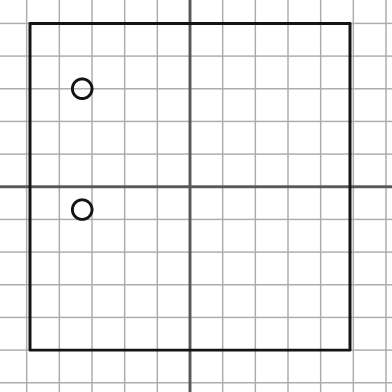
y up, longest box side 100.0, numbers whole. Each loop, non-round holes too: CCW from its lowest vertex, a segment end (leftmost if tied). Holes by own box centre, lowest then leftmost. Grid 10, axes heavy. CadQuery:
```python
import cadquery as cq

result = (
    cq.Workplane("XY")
    .moveTo(-49.0, -50.0)
    .lineTo(49.0, -50.0)
    .lineTo(49.0, 50.0)
    .lineTo(-49.0, 50.0)
    .close()
    .moveTo(-33.0, -7.0)
    .circle(3.0)
    .moveTo(-33.0, 30.0)
    .circle(3.0)
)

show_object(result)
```